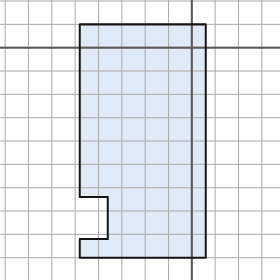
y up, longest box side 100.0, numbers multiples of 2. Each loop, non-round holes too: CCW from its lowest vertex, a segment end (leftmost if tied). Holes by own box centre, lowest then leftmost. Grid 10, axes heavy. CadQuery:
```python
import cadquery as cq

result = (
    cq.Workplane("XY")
    .moveTo(-48.0, -90.0)
    .lineTo(6.0, -90.0)
    .lineTo(6.0, 10.0)
    .lineTo(-48.0, 10.0)
    .lineTo(-48.0, -64.0)
    .lineTo(-36.0, -64.0)
    .lineTo(-36.0, -82.0)
    .lineTo(-48.0, -82.0)
    .close()
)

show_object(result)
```